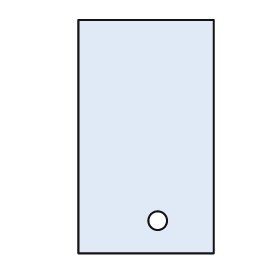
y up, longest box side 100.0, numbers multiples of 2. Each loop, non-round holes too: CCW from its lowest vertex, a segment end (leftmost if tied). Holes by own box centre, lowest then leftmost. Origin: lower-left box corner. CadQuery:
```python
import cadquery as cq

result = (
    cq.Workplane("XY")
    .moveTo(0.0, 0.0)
    .lineTo(58.0, 0.0)
    .lineTo(58.0, 100.0)
    .lineTo(0.0, 100.0)
    .close()
    .moveTo(34.0, 14.0)
    .circle(4.0)
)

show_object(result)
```